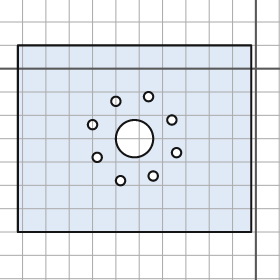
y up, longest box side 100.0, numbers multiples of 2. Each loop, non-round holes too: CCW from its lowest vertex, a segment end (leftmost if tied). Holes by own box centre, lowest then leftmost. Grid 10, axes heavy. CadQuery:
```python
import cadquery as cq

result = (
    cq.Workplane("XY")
    .moveTo(-102.0, -70.0)
    .lineTo(-2.0, -70.0)
    .lineTo(-2.0, 10.0)
    .lineTo(-102.0, 10.0)
    .close()
    .moveTo(-58.0, -48.0)
    .circle(2.0)
    .moveTo(-44.0, -46.0)
    .circle(2.0)
    .moveTo(-68.0, -38.0)
    .circle(2.0)
    .moveTo(-34.0, -36.0)
    .circle(2.0)
    .moveTo(-52.0, -30.0)
    .circle(8.0)
    .moveTo(-70.0, -24.0)
    .circle(2.0)
    .moveTo(-36.0, -22.0)
    .circle(2.0)
    .moveTo(-60.0, -14.0)
    .circle(2.0)
    .moveTo(-46.0, -12.0)
    .circle(2.0)
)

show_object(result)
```